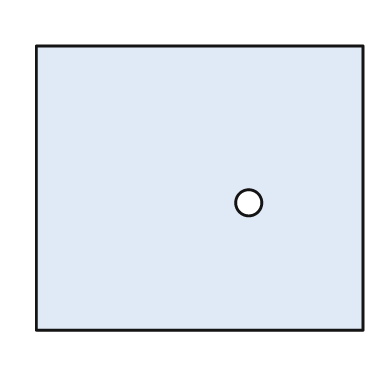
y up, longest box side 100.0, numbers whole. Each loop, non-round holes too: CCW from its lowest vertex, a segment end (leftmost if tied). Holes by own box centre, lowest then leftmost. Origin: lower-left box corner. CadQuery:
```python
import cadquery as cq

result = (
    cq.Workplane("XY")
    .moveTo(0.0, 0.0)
    .lineTo(100.0, 0.0)
    .lineTo(100.0, 87.0)
    .lineTo(0.0, 87.0)
    .close()
    .moveTo(65.0, 39.0)
    .circle(4.0)
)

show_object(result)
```